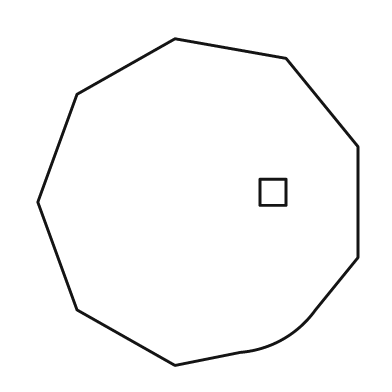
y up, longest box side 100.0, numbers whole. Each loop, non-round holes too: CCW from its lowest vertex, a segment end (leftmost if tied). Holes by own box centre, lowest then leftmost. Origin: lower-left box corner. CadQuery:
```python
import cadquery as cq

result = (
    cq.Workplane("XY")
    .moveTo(42.0, 0.0)
    .lineTo(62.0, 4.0)
    .threePointArc((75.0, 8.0), (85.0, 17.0))
    .lineTo(98.0, 33.0)
    .lineTo(98.0, 67.0)
    .lineTo(76.0, 94.0)
    .lineTo(42.0, 100.0)
    .lineTo(12.0, 83.0)
    .lineTo(0.0, 50.0)
    .lineTo(12.0, 17.0)
    .close()
    .moveTo(68.0, 49.0)
    .lineTo(76.0, 49.0)
    .lineTo(76.0, 57.0)
    .lineTo(68.0, 57.0)
    .close()
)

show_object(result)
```